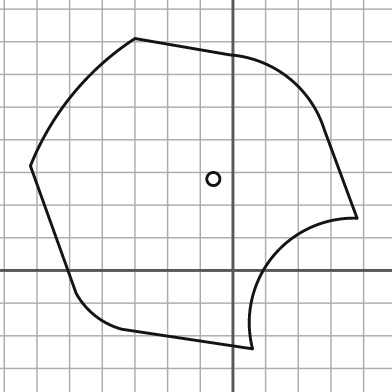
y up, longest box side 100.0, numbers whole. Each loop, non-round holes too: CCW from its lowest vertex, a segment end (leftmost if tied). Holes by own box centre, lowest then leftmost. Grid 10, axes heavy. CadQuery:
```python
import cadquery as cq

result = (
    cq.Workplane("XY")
    .moveTo(6.0, -24.0)
    .threePointArc((12.0, 4.0), (38.0, 16.0))
    .lineTo(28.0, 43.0)
    .threePointArc((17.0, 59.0), (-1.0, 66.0))
    .lineTo(-30.0, 71.0)
    .threePointArc((-49.0, 54.0), (-62.0, 32.0))
    .lineTo(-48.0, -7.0)
    .threePointArc((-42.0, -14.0), (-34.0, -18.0))
    .close()
    .moveTo(-6.0, 28.0)
    .circle(2.0)
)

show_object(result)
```